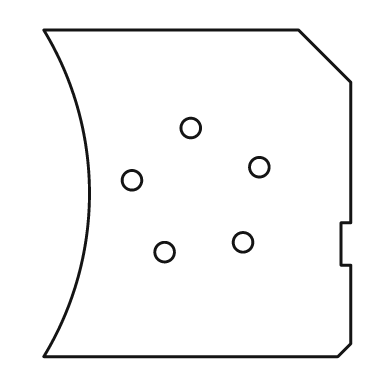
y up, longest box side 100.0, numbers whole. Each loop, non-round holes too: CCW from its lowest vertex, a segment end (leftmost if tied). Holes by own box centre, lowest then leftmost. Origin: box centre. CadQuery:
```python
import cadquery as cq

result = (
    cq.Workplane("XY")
    .moveTo(-47.0, -50.0)
    .lineTo(43.0, -50.0)
    .lineTo(47.0, -46.0)
    .lineTo(47.0, -22.0)
    .lineTo(44.0, -22.0)
    .lineTo(44.0, -9.0)
    .lineTo(47.0, -9.0)
    .lineTo(47.0, 34.0)
    .lineTo(31.0, 50.0)
    .lineTo(-47.0, 50.0)
    .threePointArc((-33.0, 0.0), (-47.0, -50.0))
    .close()
    .moveTo(-10.0, -18.0)
    .circle(3.0)
    .moveTo(14.0, -15.0)
    .circle(3.0)
    .moveTo(-20.0, 4.0)
    .circle(3.0)
    .moveTo(19.0, 8.0)
    .circle(3.0)
    .moveTo(-2.0, 20.0)
    .circle(3.0)
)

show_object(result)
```